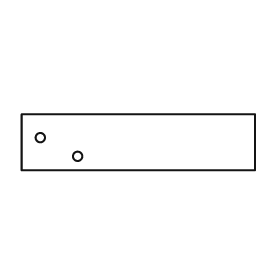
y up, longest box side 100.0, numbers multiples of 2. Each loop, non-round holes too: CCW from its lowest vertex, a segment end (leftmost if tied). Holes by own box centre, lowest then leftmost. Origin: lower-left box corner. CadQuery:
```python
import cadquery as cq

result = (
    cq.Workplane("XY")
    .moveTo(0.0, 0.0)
    .lineTo(100.0, 0.0)
    .lineTo(100.0, 24.0)
    .lineTo(0.0, 24.0)
    .close()
    .moveTo(24.0, 6.0)
    .circle(2.0)
    .moveTo(8.0, 14.0)
    .circle(2.0)
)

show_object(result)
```